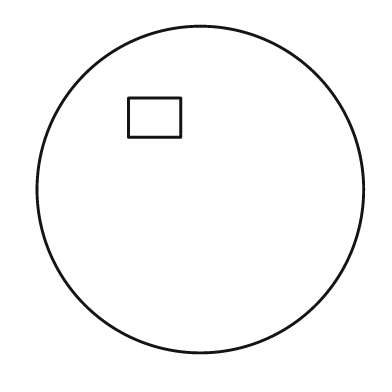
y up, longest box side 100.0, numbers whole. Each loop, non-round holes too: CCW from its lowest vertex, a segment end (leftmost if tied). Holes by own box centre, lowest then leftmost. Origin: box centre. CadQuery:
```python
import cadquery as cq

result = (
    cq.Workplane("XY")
    .moveTo(0.0, 0.0)
    .circle(50.0)
    .moveTo(-22.0, 16.0)
    .lineTo(-6.0, 16.0)
    .lineTo(-6.0, 28.0)
    .lineTo(-22.0, 28.0)
    .close()
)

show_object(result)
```